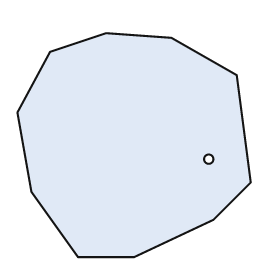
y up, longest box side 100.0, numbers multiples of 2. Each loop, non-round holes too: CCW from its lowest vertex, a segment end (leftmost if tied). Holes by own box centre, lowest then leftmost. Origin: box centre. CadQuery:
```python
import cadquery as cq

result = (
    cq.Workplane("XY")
    .moveTo(-24.0, -48.0)
    .lineTo(0.0, -48.0)
    .lineTo(34.0, -32.0)
    .lineTo(50.0, -16.0)
    .lineTo(44.0, 30.0)
    .lineTo(16.0, 46.0)
    .lineTo(-12.0, 48.0)
    .lineTo(-36.0, 40.0)
    .lineTo(-50.0, 14.0)
    .lineTo(-44.0, -20.0)
    .close()
    .moveTo(32.0, -6.0)
    .circle(2.0)
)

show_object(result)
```